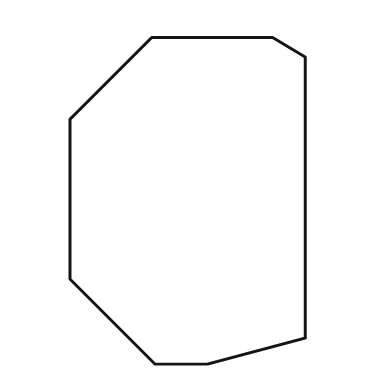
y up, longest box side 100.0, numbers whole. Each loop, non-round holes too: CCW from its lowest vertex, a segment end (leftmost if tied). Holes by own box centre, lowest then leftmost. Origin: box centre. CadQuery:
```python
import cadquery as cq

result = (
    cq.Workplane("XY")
    .moveTo(-10.0, -50.0)
    .lineTo(6.0, -50.0)
    .lineTo(36.0, -42.0)
    .lineTo(36.0, 44.0)
    .lineTo(26.0, 50.0)
    .lineTo(-11.0, 50.0)
    .lineTo(-36.0, 25.0)
    .lineTo(-36.0, -24.0)
    .close()
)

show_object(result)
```